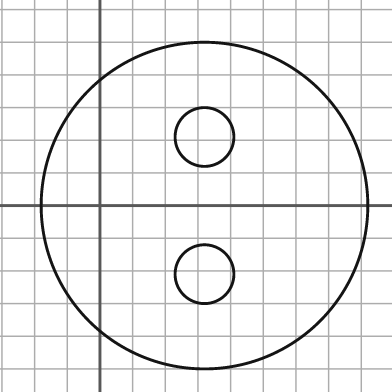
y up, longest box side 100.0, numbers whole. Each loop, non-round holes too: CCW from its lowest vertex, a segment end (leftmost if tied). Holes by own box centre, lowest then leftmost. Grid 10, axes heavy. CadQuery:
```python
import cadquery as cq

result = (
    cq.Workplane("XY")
    .moveTo(32.0, 0.0)
    .circle(50.0)
    .moveTo(32.0, -21.0)
    .circle(9.0)
    .moveTo(32.0, 21.0)
    .circle(9.0)
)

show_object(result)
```